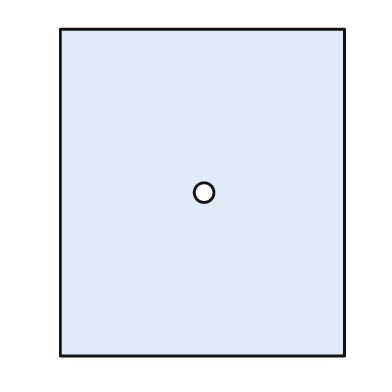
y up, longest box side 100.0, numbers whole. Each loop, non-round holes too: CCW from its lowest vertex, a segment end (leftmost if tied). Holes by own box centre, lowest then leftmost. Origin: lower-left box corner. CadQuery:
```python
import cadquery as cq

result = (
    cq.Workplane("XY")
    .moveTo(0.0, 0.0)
    .lineTo(87.0, 0.0)
    .lineTo(87.0, 100.0)
    .lineTo(0.0, 100.0)
    .close()
    .moveTo(44.0, 50.0)
    .circle(3.0)
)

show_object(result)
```